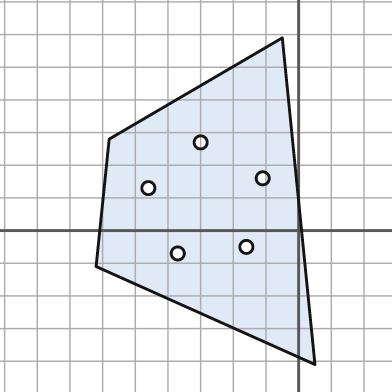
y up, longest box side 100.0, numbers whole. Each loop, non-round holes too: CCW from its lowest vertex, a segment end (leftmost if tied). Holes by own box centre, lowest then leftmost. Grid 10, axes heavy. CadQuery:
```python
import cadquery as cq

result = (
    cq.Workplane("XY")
    .moveTo(5.0, -41.0)
    .lineTo(-5.0, 59.0)
    .lineTo(-58.0, 28.0)
    .lineTo(-62.0, -11.0)
    .close()
    .moveTo(-37.0, -7.0)
    .circle(2.0)
    .moveTo(-16.0, -5.0)
    .circle(2.0)
    .moveTo(-46.0, 13.0)
    .circle(2.0)
    .moveTo(-11.0, 16.0)
    .circle(2.0)
    .moveTo(-30.0, 27.0)
    .circle(2.0)
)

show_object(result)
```